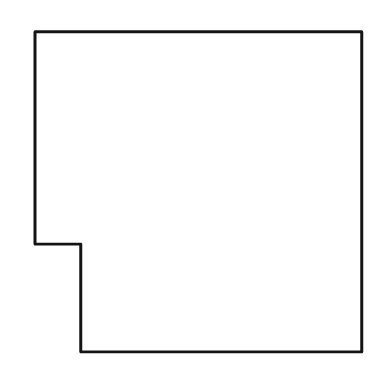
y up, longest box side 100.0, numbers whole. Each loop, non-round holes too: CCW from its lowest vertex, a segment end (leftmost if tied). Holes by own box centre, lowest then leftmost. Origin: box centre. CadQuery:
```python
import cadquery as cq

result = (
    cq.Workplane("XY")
    .moveTo(-36.0, -49.0)
    .lineTo(50.0, -49.0)
    .lineTo(50.0, 49.0)
    .lineTo(-50.0, 49.0)
    .lineTo(-50.0, -16.0)
    .lineTo(-36.0, -16.0)
    .close()
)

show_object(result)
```